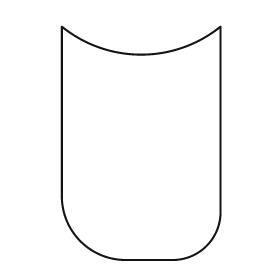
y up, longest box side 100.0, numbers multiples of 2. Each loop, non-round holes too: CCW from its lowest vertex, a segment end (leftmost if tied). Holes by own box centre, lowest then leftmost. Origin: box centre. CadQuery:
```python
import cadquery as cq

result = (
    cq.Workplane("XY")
    .moveTo(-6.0, -50.0)
    .lineTo(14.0, -50.0)
    .threePointArc((28.0, -44.0), (34.0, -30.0))
    .lineTo(34.0, 50.0)
    .threePointArc((0.0, 38.0), (-34.0, 50.0))
    .lineTo(-34.0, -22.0)
    .threePointArc((-26.0, -42.0), (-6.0, -50.0))
    .close()
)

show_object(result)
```